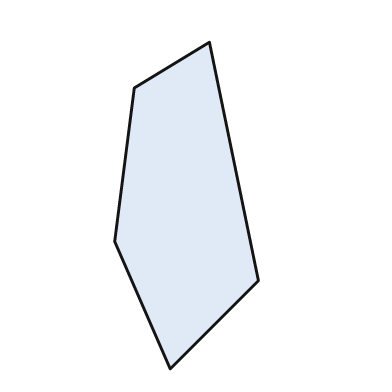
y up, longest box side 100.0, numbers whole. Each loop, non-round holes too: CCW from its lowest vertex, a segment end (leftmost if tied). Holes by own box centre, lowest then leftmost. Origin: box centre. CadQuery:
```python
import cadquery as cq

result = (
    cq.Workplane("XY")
    .moveTo(-5.0, -50.0)
    .lineTo(22.0, -23.0)
    .lineTo(7.0, 50.0)
    .lineTo(-16.0, 36.0)
    .lineTo(-22.0, -11.0)
    .close()
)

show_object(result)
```